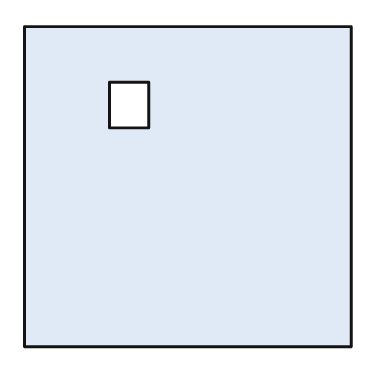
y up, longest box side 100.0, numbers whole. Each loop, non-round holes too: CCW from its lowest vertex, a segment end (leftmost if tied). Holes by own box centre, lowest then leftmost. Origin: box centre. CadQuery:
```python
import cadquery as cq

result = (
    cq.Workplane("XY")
    .moveTo(-50.0, -49.0)
    .lineTo(50.0, -49.0)
    .lineTo(50.0, 49.0)
    .lineTo(-50.0, 49.0)
    .close()
    .moveTo(-24.0, 18.0)
    .lineTo(-12.0, 18.0)
    .lineTo(-12.0, 32.0)
    .lineTo(-24.0, 32.0)
    .close()
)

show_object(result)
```